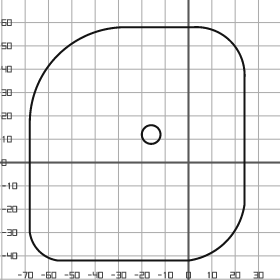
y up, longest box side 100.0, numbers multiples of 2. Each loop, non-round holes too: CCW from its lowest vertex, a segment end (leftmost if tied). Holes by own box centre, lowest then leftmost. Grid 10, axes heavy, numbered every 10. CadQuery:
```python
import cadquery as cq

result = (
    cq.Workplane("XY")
    .moveTo(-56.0, -42.0)
    .lineTo(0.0, -42.0)
    .threePointArc((16.0, -34.0), (24.0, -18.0))
    .lineTo(24.0, 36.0)
    .threePointArc((18.0, 52.0), (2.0, 58.0))
    .lineTo(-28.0, 58.0)
    .threePointArc((-56.0, 46.0), (-68.0, 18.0))
    .lineTo(-68.0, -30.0)
    .threePointArc((-64.0, -38.0), (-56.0, -42.0))
    .close()
    .moveTo(-16.0, 12.0)
    .circle(4.0)
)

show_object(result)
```